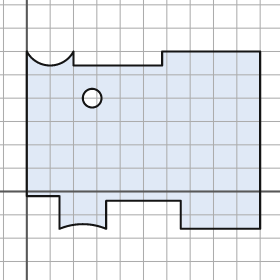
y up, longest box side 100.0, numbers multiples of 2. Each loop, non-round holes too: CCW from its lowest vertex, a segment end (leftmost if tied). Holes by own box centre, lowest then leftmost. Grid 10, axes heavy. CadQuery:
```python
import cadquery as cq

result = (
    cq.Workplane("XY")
    .moveTo(14.0, -16.0)
    .threePointArc((24.0, -14.0), (34.0, -16.0))
    .lineTo(34.0, -4.0)
    .lineTo(66.0, -4.0)
    .lineTo(66.0, -16.0)
    .lineTo(100.0, -16.0)
    .lineTo(100.0, 60.0)
    .lineTo(58.0, 60.0)
    .lineTo(58.0, 54.0)
    .lineTo(20.0, 54.0)
    .lineTo(20.0, 60.0)
    .threePointArc((10.0, 54.0), (0.0, 60.0))
    .lineTo(0.0, -2.0)
    .lineTo(14.0, -2.0)
    .close()
    .moveTo(28.0, 40.0)
    .circle(4.0)
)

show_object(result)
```